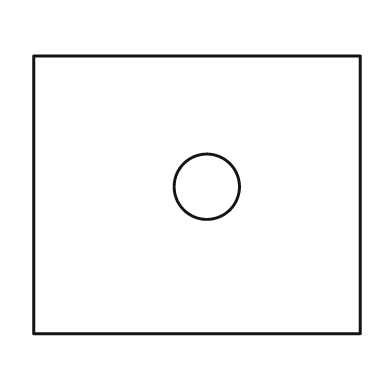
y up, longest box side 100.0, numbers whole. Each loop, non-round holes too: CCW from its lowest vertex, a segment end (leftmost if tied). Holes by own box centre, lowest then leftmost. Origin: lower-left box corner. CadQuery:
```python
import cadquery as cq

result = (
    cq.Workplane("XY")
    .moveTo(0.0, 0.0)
    .lineTo(100.0, 0.0)
    .lineTo(100.0, 85.0)
    .lineTo(0.0, 85.0)
    .close()
    .moveTo(53.0, 45.0)
    .circle(10.0)
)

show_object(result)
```